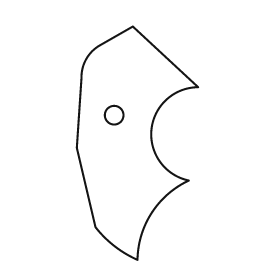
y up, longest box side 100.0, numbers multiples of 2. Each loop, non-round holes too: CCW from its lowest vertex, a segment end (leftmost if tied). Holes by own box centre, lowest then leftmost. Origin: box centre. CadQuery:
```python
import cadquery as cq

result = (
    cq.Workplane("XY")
    .moveTo(0.0, -50.0)
    .threePointArc((6.0, -30.0), (22.0, -16.0))
    .threePointArc((6.0, 6.0), (26.0, 24.0))
    .lineTo(-2.0, 50.0)
    .lineTo(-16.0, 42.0)
    .threePointArc((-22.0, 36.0), (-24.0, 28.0))
    .lineTo(-26.0, -2.0)
    .lineTo(-18.0, -36.0)
    .threePointArc((-10.0, -44.0), (0.0, -50.0))
    .close()
    .moveTo(-10.0, 12.0)
    .circle(4.0)
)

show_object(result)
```